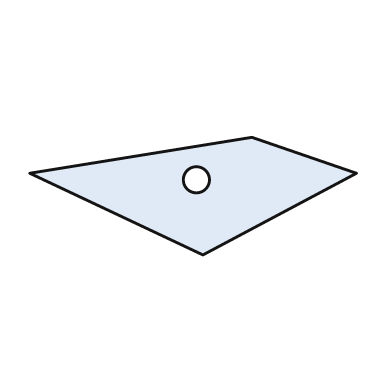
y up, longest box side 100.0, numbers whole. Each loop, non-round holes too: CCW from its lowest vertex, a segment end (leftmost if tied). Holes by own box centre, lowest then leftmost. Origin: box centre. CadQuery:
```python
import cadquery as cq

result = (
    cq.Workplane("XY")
    .moveTo(3.0, -18.0)
    .lineTo(50.0, 7.0)
    .lineTo(18.0, 18.0)
    .lineTo(-50.0, 7.0)
    .close()
    .moveTo(1.0, 5.0)
    .circle(4.0)
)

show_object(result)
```